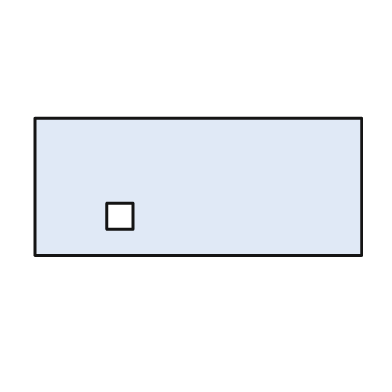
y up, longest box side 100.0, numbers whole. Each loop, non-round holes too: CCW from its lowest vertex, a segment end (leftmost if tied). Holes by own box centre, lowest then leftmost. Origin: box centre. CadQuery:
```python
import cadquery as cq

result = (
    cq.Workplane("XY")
    .moveTo(-50.0, -21.0)
    .lineTo(50.0, -21.0)
    .lineTo(50.0, 21.0)
    .lineTo(-50.0, 21.0)
    .close()
    .moveTo(-28.0, -13.0)
    .lineTo(-20.0, -13.0)
    .lineTo(-20.0, -5.0)
    .lineTo(-28.0, -5.0)
    .close()
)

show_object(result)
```